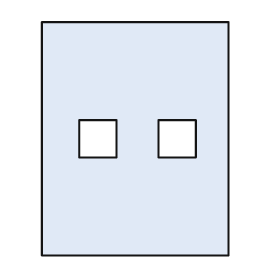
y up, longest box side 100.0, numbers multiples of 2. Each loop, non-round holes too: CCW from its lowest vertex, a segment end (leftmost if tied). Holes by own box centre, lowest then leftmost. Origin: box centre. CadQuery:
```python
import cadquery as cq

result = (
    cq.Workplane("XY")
    .moveTo(-40.0, -50.0)
    .lineTo(40.0, -50.0)
    .lineTo(40.0, 50.0)
    .lineTo(-40.0, 50.0)
    .close()
    .moveTo(-24.0, -8.0)
    .lineTo(-8.0, -8.0)
    .lineTo(-8.0, 8.0)
    .lineTo(-24.0, 8.0)
    .close()
    .moveTo(10.0, -8.0)
    .lineTo(26.0, -8.0)
    .lineTo(26.0, 8.0)
    .lineTo(10.0, 8.0)
    .close()
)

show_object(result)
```